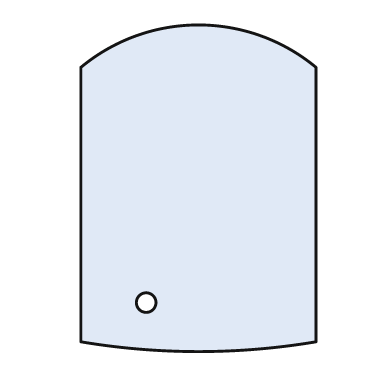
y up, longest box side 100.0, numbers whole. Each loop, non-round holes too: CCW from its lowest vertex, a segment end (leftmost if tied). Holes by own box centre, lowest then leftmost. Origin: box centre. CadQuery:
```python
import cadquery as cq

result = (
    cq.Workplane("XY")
    .moveTo(-36.0, -47.0)
    .threePointArc((0.0, -50.0), (36.0, -47.0))
    .lineTo(36.0, 37.0)
    .threePointArc((0.0, 50.0), (-36.0, 37.0))
    .close()
    .moveTo(-16.0, -35.0)
    .circle(3.0)
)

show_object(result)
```